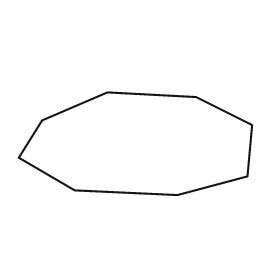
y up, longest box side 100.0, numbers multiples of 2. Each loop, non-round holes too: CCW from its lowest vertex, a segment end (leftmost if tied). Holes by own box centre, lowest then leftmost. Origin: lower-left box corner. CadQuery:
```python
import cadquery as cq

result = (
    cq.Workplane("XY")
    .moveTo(68.0, 0.0)
    .lineTo(98.0, 8.0)
    .lineTo(100.0, 30.0)
    .lineTo(76.0, 42.0)
    .lineTo(38.0, 44.0)
    .lineTo(10.0, 32.0)
    .lineTo(0.0, 16.0)
    .lineTo(24.0, 2.0)
    .close()
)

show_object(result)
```